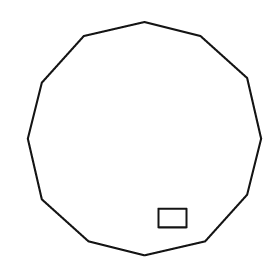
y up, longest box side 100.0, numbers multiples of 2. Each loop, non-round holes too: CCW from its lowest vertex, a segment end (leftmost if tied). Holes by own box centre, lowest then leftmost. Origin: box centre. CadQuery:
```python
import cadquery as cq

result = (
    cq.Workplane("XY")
    .moveTo(0.0, -50.0)
    .lineTo(26.0, -44.0)
    .lineTo(44.0, -24.0)
    .lineTo(50.0, 0.0)
    .lineTo(44.0, 26.0)
    .lineTo(24.0, 44.0)
    .lineTo(0.0, 50.0)
    .lineTo(-26.0, 44.0)
    .lineTo(-44.0, 24.0)
    .lineTo(-50.0, 0.0)
    .lineTo(-44.0, -26.0)
    .lineTo(-24.0, -44.0)
    .close()
    .moveTo(6.0, -38.0)
    .lineTo(18.0, -38.0)
    .lineTo(18.0, -30.0)
    .lineTo(6.0, -30.0)
    .close()
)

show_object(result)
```